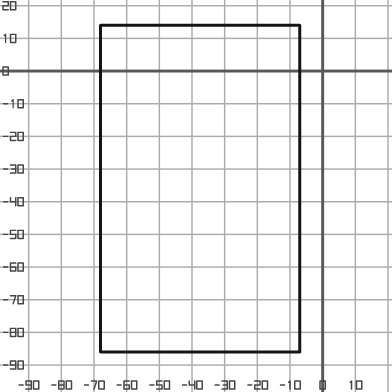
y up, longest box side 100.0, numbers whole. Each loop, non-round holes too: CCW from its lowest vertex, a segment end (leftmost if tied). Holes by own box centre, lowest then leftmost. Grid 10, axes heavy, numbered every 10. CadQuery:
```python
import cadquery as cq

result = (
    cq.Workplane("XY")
    .moveTo(-68.0, -86.0)
    .lineTo(-7.0, -86.0)
    .lineTo(-7.0, 14.0)
    .lineTo(-68.0, 14.0)
    .close()
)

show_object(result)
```